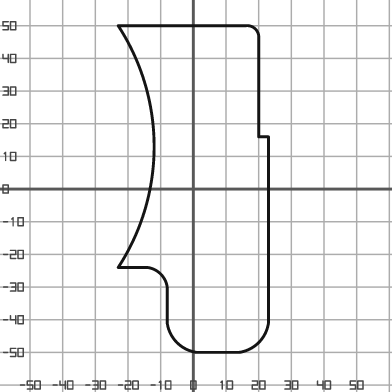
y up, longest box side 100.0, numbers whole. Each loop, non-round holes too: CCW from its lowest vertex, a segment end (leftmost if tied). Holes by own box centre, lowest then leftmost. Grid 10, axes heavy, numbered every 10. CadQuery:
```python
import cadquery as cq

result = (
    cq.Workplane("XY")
    .moveTo(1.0, -50.0)
    .lineTo(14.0, -50.0)
    .threePointArc((20.0, -47.0), (23.0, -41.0))
    .lineTo(23.0, 16.0)
    .lineTo(20.0, 16.0)
    .lineTo(20.0, 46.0)
    .threePointArc((19.0, 49.0), (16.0, 50.0))
    .lineTo(-23.0, 50.0)
    .threePointArc((-12.0, 13.0), (-23.0, -24.0))
    .lineTo(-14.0, -24.0)
    .threePointArc((-10.0, -26.0), (-8.0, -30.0))
    .lineTo(-8.0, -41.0)
    .threePointArc((-5.0, -47.0), (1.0, -50.0))
    .close()
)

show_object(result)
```